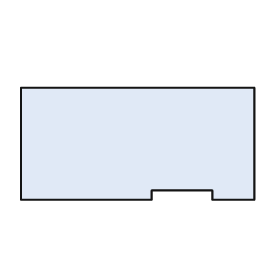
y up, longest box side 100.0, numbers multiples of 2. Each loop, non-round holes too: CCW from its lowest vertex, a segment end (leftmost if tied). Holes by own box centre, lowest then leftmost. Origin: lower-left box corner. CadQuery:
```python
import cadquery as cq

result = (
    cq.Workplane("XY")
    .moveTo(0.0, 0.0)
    .lineTo(56.0, 0.0)
    .lineTo(56.0, 4.0)
    .lineTo(82.0, 4.0)
    .lineTo(82.0, 0.0)
    .lineTo(100.0, 0.0)
    .lineTo(100.0, 48.0)
    .lineTo(0.0, 48.0)
    .close()
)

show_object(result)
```